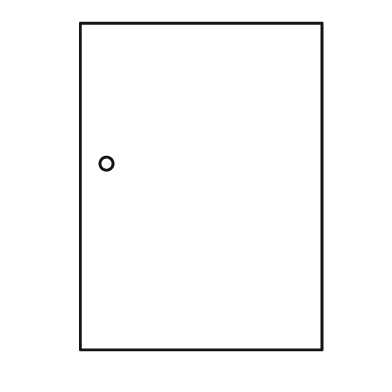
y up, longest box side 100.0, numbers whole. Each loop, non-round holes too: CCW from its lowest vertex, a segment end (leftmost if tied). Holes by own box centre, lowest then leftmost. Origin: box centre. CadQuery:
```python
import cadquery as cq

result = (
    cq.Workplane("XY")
    .moveTo(-37.0, -50.0)
    .lineTo(37.0, -50.0)
    .lineTo(37.0, 50.0)
    .lineTo(-37.0, 50.0)
    .close()
    .moveTo(-29.0, 7.0)
    .circle(2.0)
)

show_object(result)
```